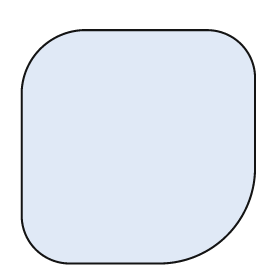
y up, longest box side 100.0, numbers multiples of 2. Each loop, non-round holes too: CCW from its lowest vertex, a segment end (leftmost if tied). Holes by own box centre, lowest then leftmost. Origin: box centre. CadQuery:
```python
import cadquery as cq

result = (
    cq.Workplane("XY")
    .moveTo(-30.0, -50.0)
    .lineTo(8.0, -50.0)
    .threePointArc((38.0, -38.0), (50.0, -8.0))
    .lineTo(50.0, 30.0)
    .threePointArc((44.0, 44.0), (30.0, 50.0))
    .lineTo(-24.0, 50.0)
    .threePointArc((-42.0, 42.0), (-50.0, 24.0))
    .lineTo(-50.0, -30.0)
    .threePointArc((-44.0, -44.0), (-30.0, -50.0))
    .close()
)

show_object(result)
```